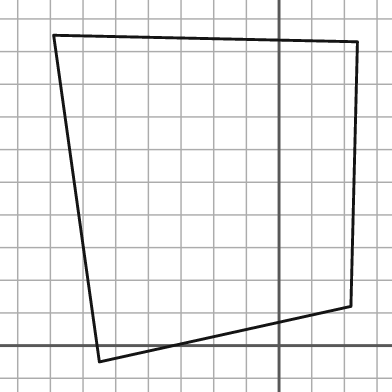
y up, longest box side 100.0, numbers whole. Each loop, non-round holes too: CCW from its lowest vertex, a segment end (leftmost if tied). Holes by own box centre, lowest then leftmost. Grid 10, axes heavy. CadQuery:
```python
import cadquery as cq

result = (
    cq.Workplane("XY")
    .moveTo(-55.0, -5.0)
    .lineTo(22.0, 12.0)
    .lineTo(24.0, 93.0)
    .lineTo(-69.0, 95.0)
    .close()
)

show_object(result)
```